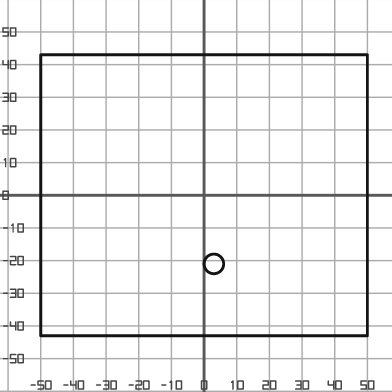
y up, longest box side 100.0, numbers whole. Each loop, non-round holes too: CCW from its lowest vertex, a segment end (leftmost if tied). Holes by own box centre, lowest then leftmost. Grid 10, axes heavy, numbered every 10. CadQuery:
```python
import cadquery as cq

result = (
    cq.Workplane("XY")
    .moveTo(-50.0, -43.0)
    .lineTo(50.0, -43.0)
    .lineTo(50.0, 43.0)
    .lineTo(-50.0, 43.0)
    .close()
    .moveTo(3.0, -21.0)
    .circle(3.0)
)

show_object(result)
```